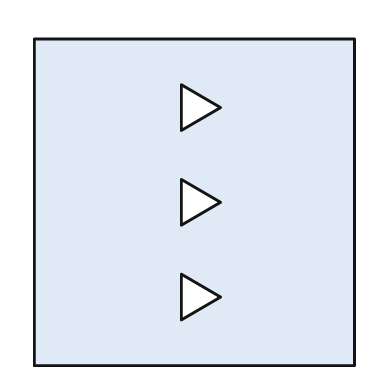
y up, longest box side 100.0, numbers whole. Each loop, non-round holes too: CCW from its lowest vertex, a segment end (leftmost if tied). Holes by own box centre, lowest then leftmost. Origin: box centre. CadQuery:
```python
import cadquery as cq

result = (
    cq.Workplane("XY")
    .moveTo(-49.0, -50.0)
    .lineTo(49.0, -50.0)
    .lineTo(49.0, 50.0)
    .lineTo(-49.0, 50.0)
    .close()
    .moveTo(-4.0, -36.0)
    .lineTo(8.0, -29.0)
    .lineTo(-4.0, -22.0)
    .close()
    .moveTo(-4.0, -7.0)
    .lineTo(8.0, 0.0)
    .lineTo(-4.0, 7.0)
    .close()
    .moveTo(-4.0, 22.0)
    .lineTo(8.0, 29.0)
    .lineTo(-4.0, 36.0)
    .close()
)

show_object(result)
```